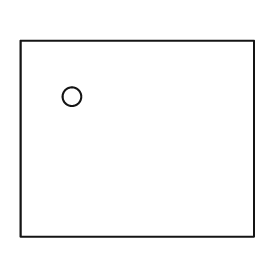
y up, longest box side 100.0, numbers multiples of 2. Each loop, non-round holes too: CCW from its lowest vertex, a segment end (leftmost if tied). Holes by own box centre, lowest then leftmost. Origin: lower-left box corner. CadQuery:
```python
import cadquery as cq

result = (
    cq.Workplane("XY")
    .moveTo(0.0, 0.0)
    .lineTo(100.0, 0.0)
    .lineTo(100.0, 84.0)
    .lineTo(0.0, 84.0)
    .close()
    .moveTo(22.0, 60.0)
    .circle(4.0)
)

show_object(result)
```